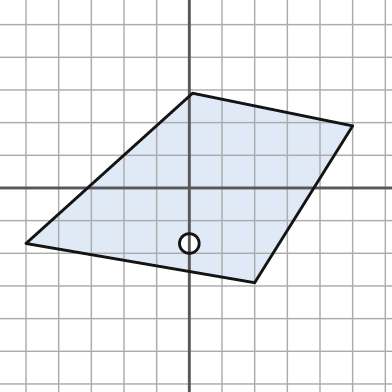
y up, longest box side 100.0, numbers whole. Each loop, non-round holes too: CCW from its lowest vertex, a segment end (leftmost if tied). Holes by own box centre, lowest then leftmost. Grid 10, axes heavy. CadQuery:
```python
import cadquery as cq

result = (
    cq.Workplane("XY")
    .moveTo(20.0, -29.0)
    .lineTo(50.0, 19.0)
    .lineTo(1.0, 29.0)
    .lineTo(-50.0, -17.0)
    .close()
    .moveTo(0.0, -17.0)
    .circle(3.0)
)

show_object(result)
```